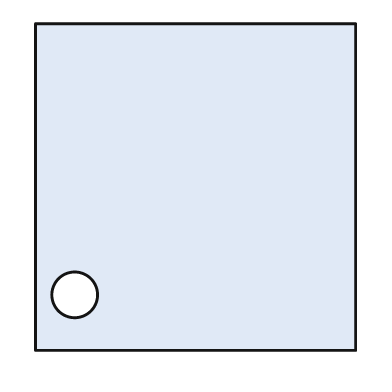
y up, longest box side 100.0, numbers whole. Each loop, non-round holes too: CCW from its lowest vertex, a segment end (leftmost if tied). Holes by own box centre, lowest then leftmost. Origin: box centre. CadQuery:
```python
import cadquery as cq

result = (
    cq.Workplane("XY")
    .moveTo(-49.0, -50.0)
    .lineTo(49.0, -50.0)
    .lineTo(49.0, 50.0)
    .lineTo(-49.0, 50.0)
    .close()
    .moveTo(-37.0, -33.0)
    .circle(7.0)
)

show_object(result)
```